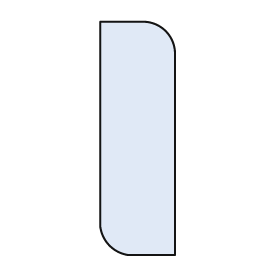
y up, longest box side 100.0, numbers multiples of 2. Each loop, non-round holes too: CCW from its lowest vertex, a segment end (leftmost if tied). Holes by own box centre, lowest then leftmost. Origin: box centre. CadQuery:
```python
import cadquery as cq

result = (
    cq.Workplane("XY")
    .moveTo(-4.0, -50.0)
    .lineTo(16.0, -50.0)
    .lineTo(16.0, 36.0)
    .threePointArc((12.0, 46.0), (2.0, 50.0))
    .lineTo(-16.0, 50.0)
    .lineTo(-16.0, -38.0)
    .threePointArc((-12.0, -46.0), (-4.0, -50.0))
    .close()
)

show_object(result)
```